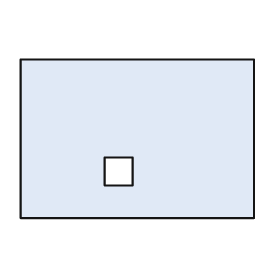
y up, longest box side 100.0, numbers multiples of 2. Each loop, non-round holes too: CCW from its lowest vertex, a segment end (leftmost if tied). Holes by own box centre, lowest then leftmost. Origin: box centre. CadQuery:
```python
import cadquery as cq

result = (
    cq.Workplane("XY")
    .moveTo(-50.0, -34.0)
    .lineTo(50.0, -34.0)
    .lineTo(50.0, 34.0)
    .lineTo(-50.0, 34.0)
    .close()
    .moveTo(-14.0, -20.0)
    .lineTo(-2.0, -20.0)
    .lineTo(-2.0, -8.0)
    .lineTo(-14.0, -8.0)
    .close()
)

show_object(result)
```